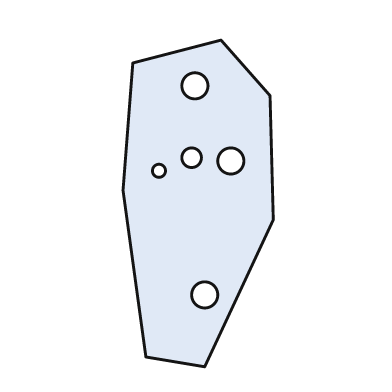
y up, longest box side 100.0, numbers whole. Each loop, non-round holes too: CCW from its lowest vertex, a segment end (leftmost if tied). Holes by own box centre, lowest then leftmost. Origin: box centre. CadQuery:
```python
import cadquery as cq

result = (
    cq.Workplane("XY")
    .moveTo(2.0, -50.0)
    .lineTo(23.0, -5.0)
    .lineTo(22.0, 33.0)
    .lineTo(7.0, 50.0)
    .lineTo(-20.0, 43.0)
    .lineTo(-23.0, 4.0)
    .lineTo(-16.0, -47.0)
    .close()
    .moveTo(2.0, -28.0)
    .circle(4.0)
    .moveTo(-12.0, 10.0)
    .circle(2.0)
    .moveTo(10.0, 13.0)
    .circle(4.0)
    .moveTo(-2.0, 14.0)
    .circle(3.0)
    .moveTo(-1.0, 36.0)
    .circle(4.0)
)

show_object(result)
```